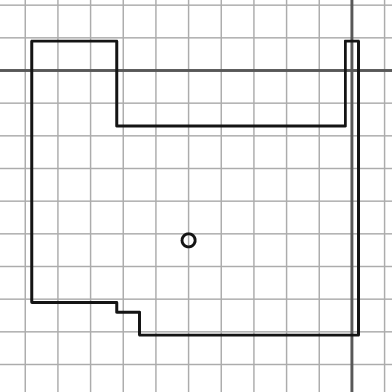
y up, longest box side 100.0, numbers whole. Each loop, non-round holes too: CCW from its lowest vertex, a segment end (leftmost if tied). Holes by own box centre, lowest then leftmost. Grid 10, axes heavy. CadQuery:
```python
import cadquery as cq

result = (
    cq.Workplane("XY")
    .moveTo(-65.0, -81.0)
    .lineTo(2.0, -81.0)
    .lineTo(2.0, 9.0)
    .lineTo(-2.0, 9.0)
    .lineTo(-2.0, -17.0)
    .lineTo(-72.0, -17.0)
    .lineTo(-72.0, 9.0)
    .lineTo(-98.0, 9.0)
    .lineTo(-98.0, -71.0)
    .lineTo(-72.0, -71.0)
    .lineTo(-72.0, -74.0)
    .lineTo(-65.0, -74.0)
    .close()
    .moveTo(-50.0, -52.0)
    .circle(2.0)
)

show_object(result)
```